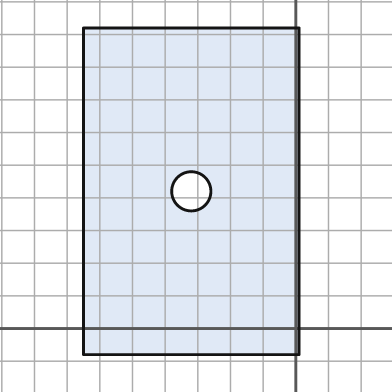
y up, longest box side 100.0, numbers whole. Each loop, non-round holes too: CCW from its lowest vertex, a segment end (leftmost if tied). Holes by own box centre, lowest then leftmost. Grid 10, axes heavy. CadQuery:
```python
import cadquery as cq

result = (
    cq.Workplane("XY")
    .moveTo(-65.0, -8.0)
    .lineTo(1.0, -8.0)
    .lineTo(1.0, 92.0)
    .lineTo(-65.0, 92.0)
    .close()
    .moveTo(-32.0, 42.0)
    .circle(6.0)
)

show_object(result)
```